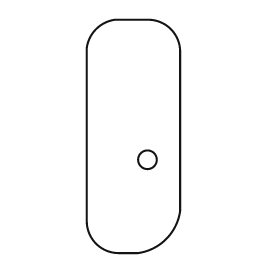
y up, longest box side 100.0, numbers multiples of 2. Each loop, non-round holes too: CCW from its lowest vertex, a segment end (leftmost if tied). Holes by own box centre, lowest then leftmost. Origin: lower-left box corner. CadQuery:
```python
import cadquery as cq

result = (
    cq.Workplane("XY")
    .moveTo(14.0, 0.0)
    .lineTo(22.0, 0.0)
    .threePointArc((34.0, 6.0), (40.0, 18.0))
    .lineTo(40.0, 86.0)
    .threePointArc((36.0, 96.0), (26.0, 100.0))
    .lineTo(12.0, 100.0)
    .threePointArc((4.0, 96.0), (0.0, 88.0))
    .lineTo(0.0, 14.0)
    .threePointArc((4.0, 4.0), (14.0, 0.0))
    .close()
    .moveTo(26.0, 40.0)
    .circle(4.0)
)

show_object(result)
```